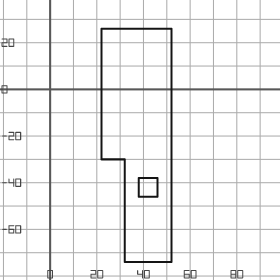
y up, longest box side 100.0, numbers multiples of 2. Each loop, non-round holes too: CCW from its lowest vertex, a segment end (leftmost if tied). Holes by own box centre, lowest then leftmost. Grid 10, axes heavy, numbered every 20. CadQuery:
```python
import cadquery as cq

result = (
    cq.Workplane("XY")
    .moveTo(32.0, -74.0)
    .lineTo(52.0, -74.0)
    .lineTo(52.0, 26.0)
    .lineTo(22.0, 26.0)
    .lineTo(22.0, -30.0)
    .lineTo(32.0, -30.0)
    .close()
    .moveTo(38.0, -46.0)
    .lineTo(46.0, -46.0)
    .lineTo(46.0, -38.0)
    .lineTo(38.0, -38.0)
    .close()
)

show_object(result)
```